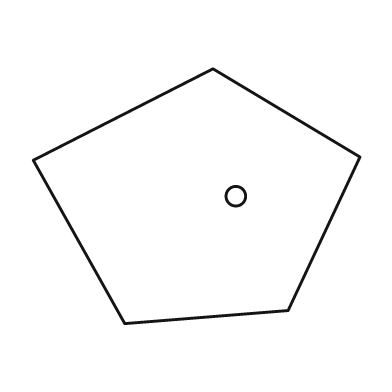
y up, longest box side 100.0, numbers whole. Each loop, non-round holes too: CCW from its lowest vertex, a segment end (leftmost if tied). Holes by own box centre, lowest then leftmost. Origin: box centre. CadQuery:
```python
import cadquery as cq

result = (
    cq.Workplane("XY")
    .moveTo(-22.0, -39.0)
    .lineTo(28.0, -35.0)
    .lineTo(50.0, 12.0)
    .lineTo(5.0, 39.0)
    .lineTo(-50.0, 11.0)
    .close()
    .moveTo(12.0, 0.0)
    .circle(3.0)
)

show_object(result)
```